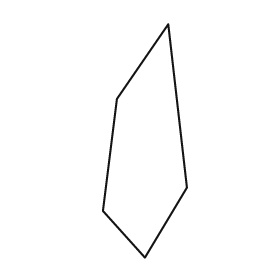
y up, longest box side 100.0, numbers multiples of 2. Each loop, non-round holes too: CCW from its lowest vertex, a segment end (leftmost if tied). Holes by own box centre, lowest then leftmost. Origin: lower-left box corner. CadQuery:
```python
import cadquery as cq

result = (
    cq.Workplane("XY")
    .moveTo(18.0, 0.0)
    .lineTo(36.0, 30.0)
    .lineTo(28.0, 100.0)
    .lineTo(6.0, 68.0)
    .lineTo(0.0, 20.0)
    .close()
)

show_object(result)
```